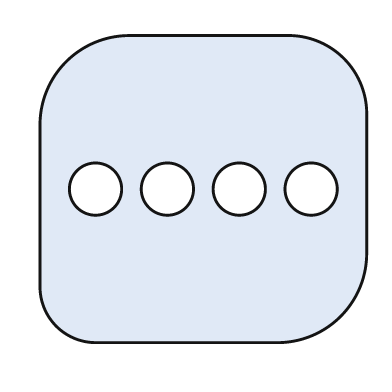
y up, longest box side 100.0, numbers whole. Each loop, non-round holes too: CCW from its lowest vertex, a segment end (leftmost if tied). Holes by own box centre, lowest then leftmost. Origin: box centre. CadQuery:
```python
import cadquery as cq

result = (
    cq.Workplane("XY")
    .moveTo(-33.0, -47.0)
    .lineTo(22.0, -47.0)
    .threePointArc((42.0, -39.0), (50.0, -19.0))
    .lineTo(50.0, 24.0)
    .threePointArc((43.0, 40.0), (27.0, 47.0))
    .lineTo(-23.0, 47.0)
    .threePointArc((-42.0, 39.0), (-50.0, 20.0))
    .lineTo(-50.0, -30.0)
    .threePointArc((-45.0, -42.0), (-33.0, -47.0))
    .close()
    .moveTo(-33.0, 0.0)
    .circle(8.0)
    .moveTo(-11.0, 0.0)
    .circle(8.0)
    .moveTo(11.0, 0.0)
    .circle(8.0)
    .moveTo(33.0, 0.0)
    .circle(8.0)
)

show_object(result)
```